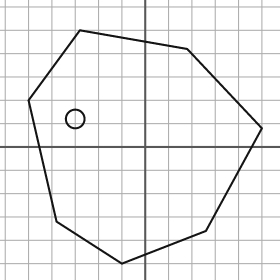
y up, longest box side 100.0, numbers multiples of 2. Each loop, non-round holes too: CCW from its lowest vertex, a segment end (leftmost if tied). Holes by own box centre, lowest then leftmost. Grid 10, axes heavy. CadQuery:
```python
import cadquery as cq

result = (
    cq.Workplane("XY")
    .moveTo(-10.0, -50.0)
    .lineTo(26.0, -36.0)
    .lineTo(50.0, 8.0)
    .lineTo(18.0, 42.0)
    .lineTo(-28.0, 50.0)
    .lineTo(-50.0, 20.0)
    .lineTo(-38.0, -32.0)
    .close()
    .moveTo(-30.0, 12.0)
    .circle(4.0)
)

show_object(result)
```